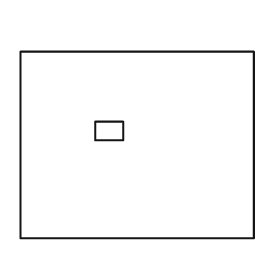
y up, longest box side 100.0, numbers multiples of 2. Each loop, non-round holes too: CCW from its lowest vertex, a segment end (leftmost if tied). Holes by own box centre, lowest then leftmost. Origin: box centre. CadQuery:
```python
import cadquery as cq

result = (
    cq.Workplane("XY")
    .moveTo(-50.0, -40.0)
    .lineTo(50.0, -40.0)
    .lineTo(50.0, 40.0)
    .lineTo(-50.0, 40.0)
    .close()
    .moveTo(-18.0, 2.0)
    .lineTo(-6.0, 2.0)
    .lineTo(-6.0, 10.0)
    .lineTo(-18.0, 10.0)
    .close()
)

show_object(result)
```